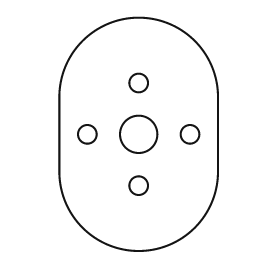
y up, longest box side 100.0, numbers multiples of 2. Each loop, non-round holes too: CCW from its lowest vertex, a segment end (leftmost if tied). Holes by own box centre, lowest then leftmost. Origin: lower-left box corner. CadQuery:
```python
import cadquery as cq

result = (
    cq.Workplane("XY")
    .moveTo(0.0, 34.0)
    .threePointArc((34.0, 0.0), (68.0, 34.0))
    .lineTo(68.0, 66.0)
    .threePointArc((34.0, 100.0), (0.0, 66.0))
    .close()
    .moveTo(34.0, 28.0)
    .circle(4.0)
    .moveTo(12.0, 50.0)
    .circle(4.0)
    .moveTo(34.0, 50.0)
    .circle(8.0)
    .moveTo(56.0, 50.0)
    .circle(4.0)
    .moveTo(34.0, 72.0)
    .circle(4.0)
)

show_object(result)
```